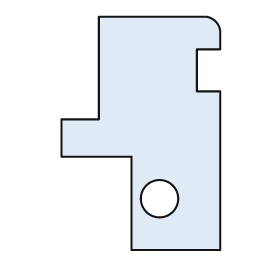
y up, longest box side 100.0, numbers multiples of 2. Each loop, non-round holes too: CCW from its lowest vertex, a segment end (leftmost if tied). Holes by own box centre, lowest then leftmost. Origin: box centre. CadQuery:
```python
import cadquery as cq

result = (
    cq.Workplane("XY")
    .moveTo(-4.0, -50.0)
    .lineTo(34.0, -50.0)
    .lineTo(34.0, 18.0)
    .lineTo(24.0, 18.0)
    .lineTo(24.0, 36.0)
    .lineTo(34.0, 36.0)
    .lineTo(34.0, 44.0)
    .threePointArc((32.0, 48.0), (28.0, 50.0))
    .lineTo(-18.0, 50.0)
    .lineTo(-18.0, 6.0)
    .lineTo(-34.0, 6.0)
    .lineTo(-34.0, -10.0)
    .lineTo(-4.0, -10.0)
    .close()
    .moveTo(8.0, -28.0)
    .circle(8.0)
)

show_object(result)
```